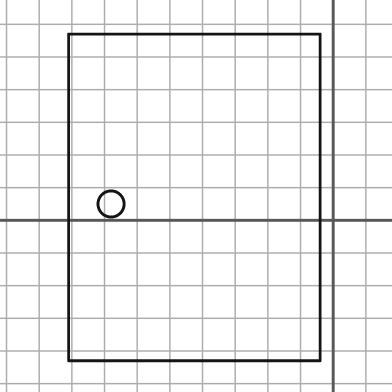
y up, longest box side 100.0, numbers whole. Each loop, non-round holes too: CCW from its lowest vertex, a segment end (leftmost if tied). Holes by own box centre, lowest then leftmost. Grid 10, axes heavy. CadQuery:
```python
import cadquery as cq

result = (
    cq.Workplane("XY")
    .moveTo(-81.0, -43.0)
    .lineTo(-4.0, -43.0)
    .lineTo(-4.0, 57.0)
    .lineTo(-81.0, 57.0)
    .close()
    .moveTo(-68.0, 5.0)
    .circle(4.0)
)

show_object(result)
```